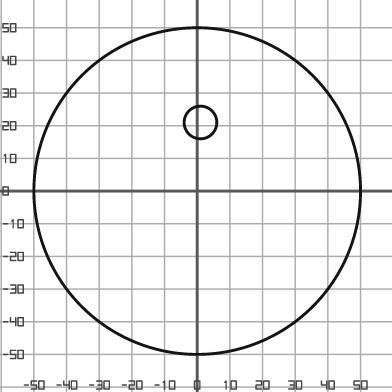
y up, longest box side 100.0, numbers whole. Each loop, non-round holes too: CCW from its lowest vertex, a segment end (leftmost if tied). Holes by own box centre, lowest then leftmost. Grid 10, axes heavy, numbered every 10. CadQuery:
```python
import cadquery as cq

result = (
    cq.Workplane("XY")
    .moveTo(0.0, 0.0)
    .circle(50.0)
    .moveTo(1.0, 21.0)
    .circle(5.0)
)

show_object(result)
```